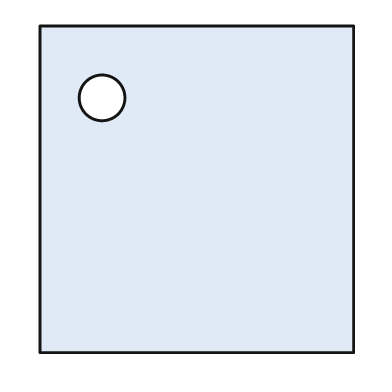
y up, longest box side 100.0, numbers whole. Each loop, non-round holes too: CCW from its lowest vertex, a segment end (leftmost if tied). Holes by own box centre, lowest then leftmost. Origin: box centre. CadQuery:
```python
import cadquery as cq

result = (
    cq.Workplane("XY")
    .moveTo(-48.0, -50.0)
    .lineTo(48.0, -50.0)
    .lineTo(48.0, 50.0)
    .lineTo(-48.0, 50.0)
    .close()
    .moveTo(-29.0, 28.0)
    .circle(7.0)
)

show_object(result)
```